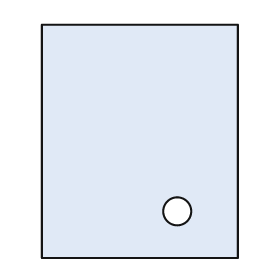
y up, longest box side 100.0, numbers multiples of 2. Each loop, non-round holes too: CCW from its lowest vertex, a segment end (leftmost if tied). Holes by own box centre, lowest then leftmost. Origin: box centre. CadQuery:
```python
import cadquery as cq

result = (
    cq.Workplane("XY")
    .moveTo(-42.0, -50.0)
    .lineTo(42.0, -50.0)
    .lineTo(42.0, 50.0)
    .lineTo(-42.0, 50.0)
    .close()
    .moveTo(16.0, -30.0)
    .circle(6.0)
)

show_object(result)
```